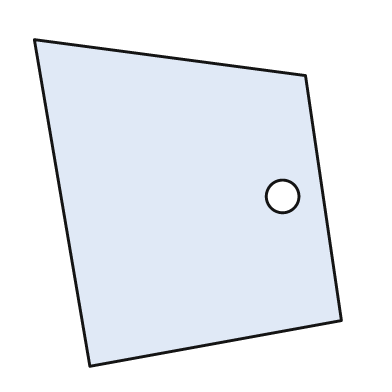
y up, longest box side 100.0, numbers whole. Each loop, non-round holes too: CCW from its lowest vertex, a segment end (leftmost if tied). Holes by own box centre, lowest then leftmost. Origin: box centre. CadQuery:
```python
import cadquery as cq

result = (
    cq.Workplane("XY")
    .moveTo(-30.0, -50.0)
    .lineTo(47.0, -36.0)
    .lineTo(36.0, 39.0)
    .lineTo(-47.0, 50.0)
    .close()
    .moveTo(29.0, 2.0)
    .circle(5.0)
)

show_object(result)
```